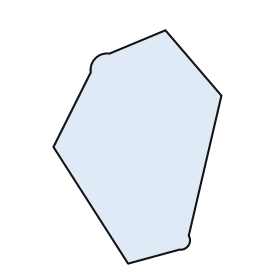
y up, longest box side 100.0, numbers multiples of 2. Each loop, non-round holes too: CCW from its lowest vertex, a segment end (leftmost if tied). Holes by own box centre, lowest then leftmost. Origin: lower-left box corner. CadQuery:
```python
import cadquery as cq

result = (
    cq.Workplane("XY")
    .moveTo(32.0, 0.0)
    .lineTo(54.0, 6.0)
    .threePointArc((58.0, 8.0), (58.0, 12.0))
    .lineTo(72.0, 72.0)
    .lineTo(48.0, 100.0)
    .lineTo(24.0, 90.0)
    .threePointArc((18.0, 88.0), (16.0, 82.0))
    .lineTo(0.0, 50.0)
    .close()
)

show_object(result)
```